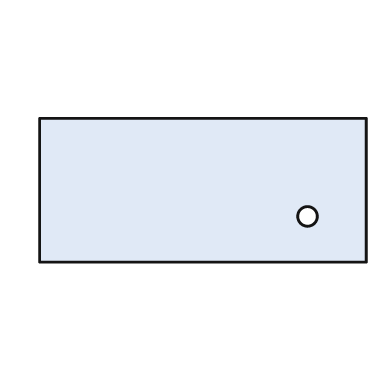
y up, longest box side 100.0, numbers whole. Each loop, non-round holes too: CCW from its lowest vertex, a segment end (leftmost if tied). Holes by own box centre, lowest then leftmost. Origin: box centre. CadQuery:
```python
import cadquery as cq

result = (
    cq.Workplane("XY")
    .moveTo(-50.0, -22.0)
    .lineTo(50.0, -22.0)
    .lineTo(50.0, 22.0)
    .lineTo(-50.0, 22.0)
    .close()
    .moveTo(32.0, -8.0)
    .circle(3.0)
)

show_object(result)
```